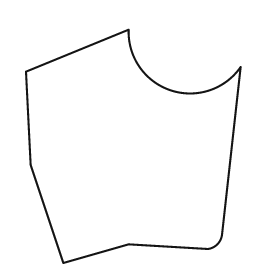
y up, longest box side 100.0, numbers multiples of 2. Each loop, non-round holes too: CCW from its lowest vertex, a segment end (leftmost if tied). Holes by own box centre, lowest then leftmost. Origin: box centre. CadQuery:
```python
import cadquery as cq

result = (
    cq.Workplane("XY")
    .moveTo(-30.0, -50.0)
    .lineTo(-2.0, -42.0)
    .lineTo(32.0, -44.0)
    .threePointArc((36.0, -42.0), (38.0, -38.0))
    .lineTo(46.0, 34.0)
    .threePointArc((16.0, 24.0), (-2.0, 50.0))
    .lineTo(-46.0, 32.0)
    .lineTo(-44.0, -8.0)
    .close()
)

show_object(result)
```